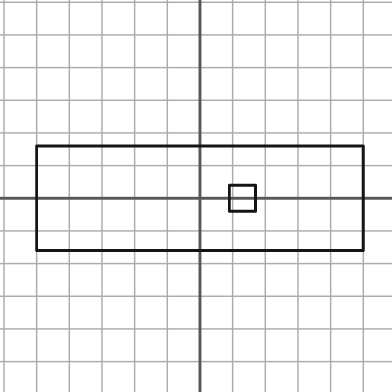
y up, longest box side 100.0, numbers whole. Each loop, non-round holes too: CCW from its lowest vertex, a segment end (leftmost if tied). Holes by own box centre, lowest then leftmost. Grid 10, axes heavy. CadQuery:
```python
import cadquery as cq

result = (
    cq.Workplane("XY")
    .moveTo(-50.0, -16.0)
    .lineTo(50.0, -16.0)
    .lineTo(50.0, 16.0)
    .lineTo(-50.0, 16.0)
    .close()
    .moveTo(9.0, -4.0)
    .lineTo(17.0, -4.0)
    .lineTo(17.0, 4.0)
    .lineTo(9.0, 4.0)
    .close()
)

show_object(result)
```